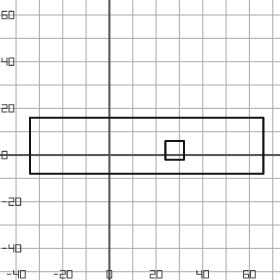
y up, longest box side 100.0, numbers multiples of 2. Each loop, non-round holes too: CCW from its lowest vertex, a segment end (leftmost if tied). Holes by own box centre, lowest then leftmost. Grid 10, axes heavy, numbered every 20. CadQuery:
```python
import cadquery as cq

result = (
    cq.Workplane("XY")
    .moveTo(-34.0, -8.0)
    .lineTo(66.0, -8.0)
    .lineTo(66.0, 16.0)
    .lineTo(-34.0, 16.0)
    .close()
    .moveTo(24.0, -2.0)
    .lineTo(32.0, -2.0)
    .lineTo(32.0, 6.0)
    .lineTo(24.0, 6.0)
    .close()
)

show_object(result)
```